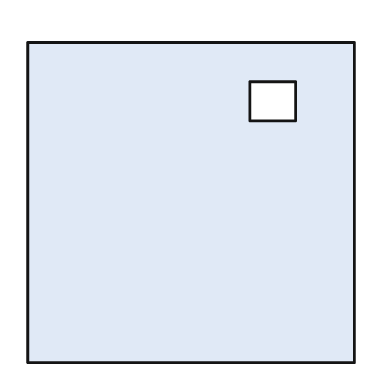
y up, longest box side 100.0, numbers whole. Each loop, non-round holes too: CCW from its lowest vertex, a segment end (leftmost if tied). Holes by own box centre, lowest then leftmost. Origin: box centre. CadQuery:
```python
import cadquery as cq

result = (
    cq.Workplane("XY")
    .moveTo(-50.0, -49.0)
    .lineTo(50.0, -49.0)
    .lineTo(50.0, 49.0)
    .lineTo(-50.0, 49.0)
    .close()
    .moveTo(18.0, 25.0)
    .lineTo(32.0, 25.0)
    .lineTo(32.0, 37.0)
    .lineTo(18.0, 37.0)
    .close()
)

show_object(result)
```